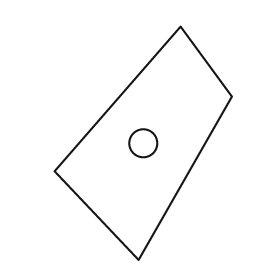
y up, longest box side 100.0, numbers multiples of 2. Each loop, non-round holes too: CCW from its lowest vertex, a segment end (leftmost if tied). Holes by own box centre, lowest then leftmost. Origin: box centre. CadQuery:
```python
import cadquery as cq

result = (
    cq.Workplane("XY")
    .moveTo(-2.0, -50.0)
    .lineTo(38.0, 20.0)
    .lineTo(16.0, 50.0)
    .lineTo(-38.0, -12.0)
    .close()
    .moveTo(0.0, 0.0)
    .circle(6.0)
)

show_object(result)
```